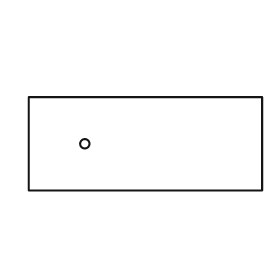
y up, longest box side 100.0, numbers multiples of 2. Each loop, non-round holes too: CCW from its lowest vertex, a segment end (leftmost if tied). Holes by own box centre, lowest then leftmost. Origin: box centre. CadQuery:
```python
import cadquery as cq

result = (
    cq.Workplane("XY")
    .moveTo(-50.0, -20.0)
    .lineTo(50.0, -20.0)
    .lineTo(50.0, 20.0)
    .lineTo(-50.0, 20.0)
    .close()
    .moveTo(-26.0, 0.0)
    .circle(2.0)
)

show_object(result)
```